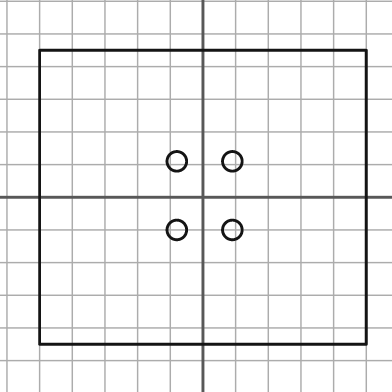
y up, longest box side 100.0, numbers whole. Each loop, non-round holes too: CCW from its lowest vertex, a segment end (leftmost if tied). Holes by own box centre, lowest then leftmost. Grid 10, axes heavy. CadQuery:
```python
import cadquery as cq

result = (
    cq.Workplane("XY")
    .moveTo(-50.0, -45.0)
    .lineTo(50.0, -45.0)
    .lineTo(50.0, 45.0)
    .lineTo(-50.0, 45.0)
    .close()
    .moveTo(-8.0, -10.0)
    .circle(3.0)
    .moveTo(9.0, -10.0)
    .circle(3.0)
    .moveTo(-8.0, 11.0)
    .circle(3.0)
    .moveTo(9.0, 11.0)
    .circle(3.0)
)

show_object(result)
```